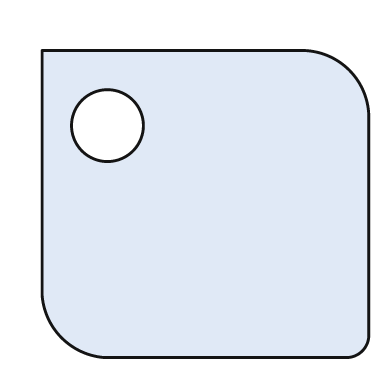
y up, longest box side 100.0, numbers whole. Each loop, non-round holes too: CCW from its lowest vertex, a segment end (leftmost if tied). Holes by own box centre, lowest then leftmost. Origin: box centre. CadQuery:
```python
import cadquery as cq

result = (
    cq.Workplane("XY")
    .moveTo(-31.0, -47.0)
    .lineTo(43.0, -47.0)
    .threePointArc((48.0, -45.0), (50.0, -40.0))
    .lineTo(50.0, 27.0)
    .threePointArc((44.0, 41.0), (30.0, 47.0))
    .lineTo(-50.0, 47.0)
    .lineTo(-50.0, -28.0)
    .threePointArc((-44.0, -41.0), (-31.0, -47.0))
    .close()
    .moveTo(-30.0, 24.0)
    .circle(11.0)
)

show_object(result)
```